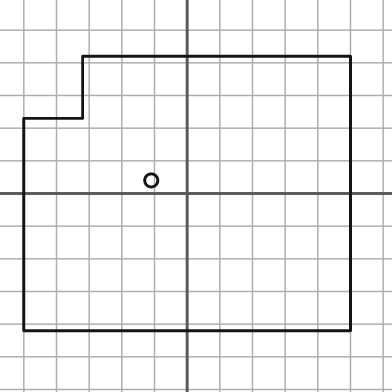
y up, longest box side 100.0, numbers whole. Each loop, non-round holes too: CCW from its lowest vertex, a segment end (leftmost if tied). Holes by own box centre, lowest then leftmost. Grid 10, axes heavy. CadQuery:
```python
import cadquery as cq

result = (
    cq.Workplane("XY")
    .moveTo(-50.0, -42.0)
    .lineTo(50.0, -42.0)
    .lineTo(50.0, 42.0)
    .lineTo(-32.0, 42.0)
    .lineTo(-32.0, 23.0)
    .lineTo(-50.0, 23.0)
    .close()
    .moveTo(-11.0, 4.0)
    .circle(2.0)
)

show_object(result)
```